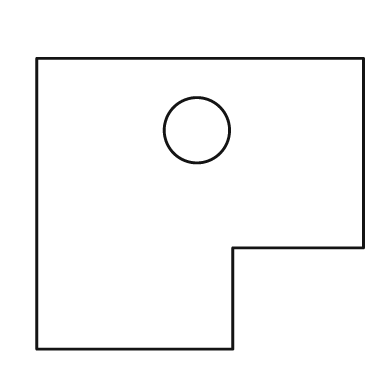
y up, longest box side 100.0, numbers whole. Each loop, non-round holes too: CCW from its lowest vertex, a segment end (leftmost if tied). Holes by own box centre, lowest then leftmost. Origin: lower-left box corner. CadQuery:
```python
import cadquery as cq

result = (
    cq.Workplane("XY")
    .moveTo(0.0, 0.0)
    .lineTo(60.0, 0.0)
    .lineTo(60.0, 31.0)
    .lineTo(100.0, 31.0)
    .lineTo(100.0, 89.0)
    .lineTo(0.0, 89.0)
    .close()
    .moveTo(49.0, 67.0)
    .circle(10.0)
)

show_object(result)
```